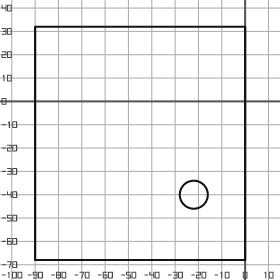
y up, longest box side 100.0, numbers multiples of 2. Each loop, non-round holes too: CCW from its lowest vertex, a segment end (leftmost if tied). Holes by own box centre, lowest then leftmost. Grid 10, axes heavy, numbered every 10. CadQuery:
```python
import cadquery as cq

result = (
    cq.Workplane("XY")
    .moveTo(-90.0, -68.0)
    .lineTo(0.0, -68.0)
    .lineTo(0.0, 32.0)
    .lineTo(-90.0, 32.0)
    .close()
    .moveTo(-22.0, -40.0)
    .circle(6.0)
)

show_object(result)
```